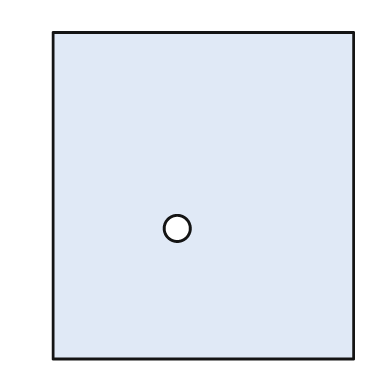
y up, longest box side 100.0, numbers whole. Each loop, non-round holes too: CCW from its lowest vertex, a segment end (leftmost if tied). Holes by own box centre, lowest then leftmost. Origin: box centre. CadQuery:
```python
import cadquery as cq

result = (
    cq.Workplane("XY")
    .moveTo(-46.0, -50.0)
    .lineTo(46.0, -50.0)
    .lineTo(46.0, 50.0)
    .lineTo(-46.0, 50.0)
    .close()
    .moveTo(-8.0, -10.0)
    .circle(4.0)
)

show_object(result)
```